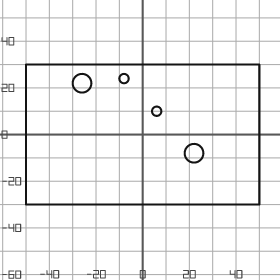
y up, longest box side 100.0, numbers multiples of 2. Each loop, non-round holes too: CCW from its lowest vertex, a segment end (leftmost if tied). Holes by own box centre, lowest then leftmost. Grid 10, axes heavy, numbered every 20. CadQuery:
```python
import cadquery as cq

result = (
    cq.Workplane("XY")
    .moveTo(-50.0, -30.0)
    .lineTo(50.0, -30.0)
    .lineTo(50.0, 30.0)
    .lineTo(-50.0, 30.0)
    .close()
    .moveTo(22.0, -8.0)
    .circle(4.0)
    .moveTo(6.0, 10.0)
    .circle(2.0)
    .moveTo(-26.0, 22.0)
    .circle(4.0)
    .moveTo(-8.0, 24.0)
    .circle(2.0)
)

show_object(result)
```